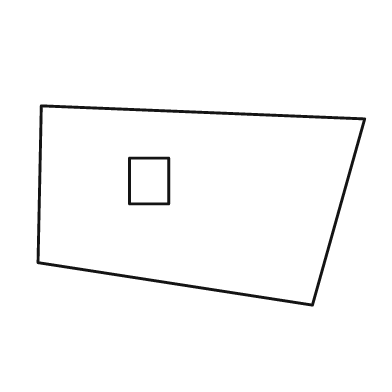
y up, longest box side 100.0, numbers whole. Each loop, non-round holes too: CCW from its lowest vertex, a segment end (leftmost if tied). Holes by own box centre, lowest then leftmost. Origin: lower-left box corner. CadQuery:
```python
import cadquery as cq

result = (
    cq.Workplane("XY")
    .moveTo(84.0, 0.0)
    .lineTo(100.0, 57.0)
    .lineTo(1.0, 61.0)
    .lineTo(0.0, 13.0)
    .close()
    .moveTo(28.0, 31.0)
    .lineTo(40.0, 31.0)
    .lineTo(40.0, 45.0)
    .lineTo(28.0, 45.0)
    .close()
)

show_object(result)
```